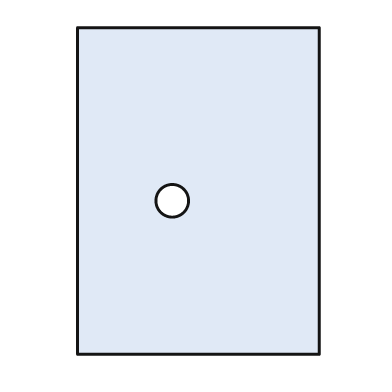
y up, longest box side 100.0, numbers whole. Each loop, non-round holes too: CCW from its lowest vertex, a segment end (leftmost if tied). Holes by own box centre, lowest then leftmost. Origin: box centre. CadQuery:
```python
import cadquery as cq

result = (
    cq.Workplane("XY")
    .moveTo(-37.0, -50.0)
    .lineTo(37.0, -50.0)
    .lineTo(37.0, 50.0)
    .lineTo(-37.0, 50.0)
    .close()
    .moveTo(-8.0, -3.0)
    .circle(5.0)
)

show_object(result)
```